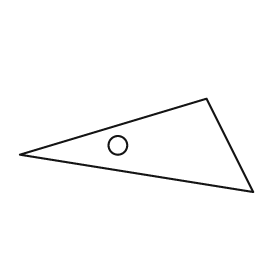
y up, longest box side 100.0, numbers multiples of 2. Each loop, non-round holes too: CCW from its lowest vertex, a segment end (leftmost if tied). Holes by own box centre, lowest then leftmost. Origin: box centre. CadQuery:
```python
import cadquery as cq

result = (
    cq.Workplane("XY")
    .moveTo(50.0, -20.0)
    .lineTo(30.0, 20.0)
    .lineTo(-50.0, -4.0)
    .close()
    .moveTo(-8.0, 0.0)
    .circle(4.0)
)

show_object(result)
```